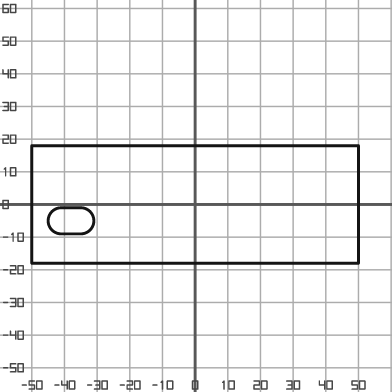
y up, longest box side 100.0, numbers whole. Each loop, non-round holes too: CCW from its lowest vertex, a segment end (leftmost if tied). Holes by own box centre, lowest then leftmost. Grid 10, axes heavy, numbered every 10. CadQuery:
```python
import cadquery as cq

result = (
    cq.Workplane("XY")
    .moveTo(-50.0, -18.0)
    .lineTo(50.0, -18.0)
    .lineTo(50.0, 18.0)
    .lineTo(-50.0, 18.0)
    .close()
    .moveTo(-41.0, -9.0)
    .lineTo(-35.0, -9.0)
    .threePointArc((-31.0, -5.0), (-35.0, -1.0))
    .lineTo(-41.0, -1.0)
    .threePointArc((-45.0, -5.0), (-41.0, -9.0))
    .close()
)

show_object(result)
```